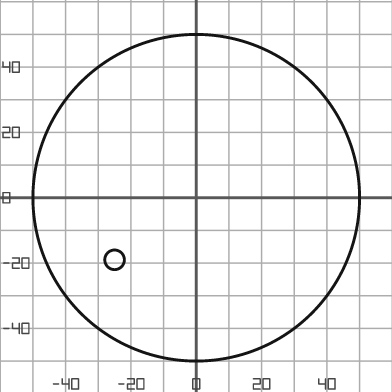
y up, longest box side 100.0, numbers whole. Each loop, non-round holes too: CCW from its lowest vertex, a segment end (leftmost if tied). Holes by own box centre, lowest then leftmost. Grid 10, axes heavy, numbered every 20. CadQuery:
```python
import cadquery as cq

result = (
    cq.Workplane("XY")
    .moveTo(0.0, 0.0)
    .circle(50.0)
    .moveTo(-25.0, -19.0)
    .circle(3.0)
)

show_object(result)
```